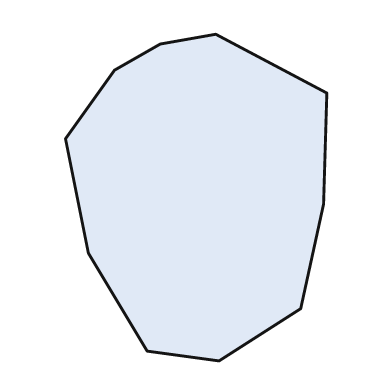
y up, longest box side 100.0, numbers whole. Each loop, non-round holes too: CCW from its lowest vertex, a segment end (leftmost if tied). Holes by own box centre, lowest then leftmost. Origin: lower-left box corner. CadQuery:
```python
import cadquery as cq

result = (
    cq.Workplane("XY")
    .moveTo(47.0, 0.0)
    .lineTo(72.0, 16.0)
    .lineTo(79.0, 48.0)
    .lineTo(80.0, 82.0)
    .lineTo(46.0, 100.0)
    .lineTo(29.0, 97.0)
    .lineTo(15.0, 89.0)
    .lineTo(0.0, 68.0)
    .lineTo(7.0, 33.0)
    .lineTo(25.0, 3.0)
    .close()
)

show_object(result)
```